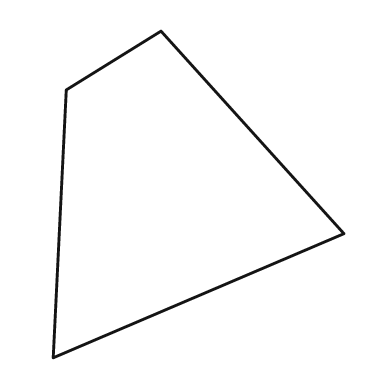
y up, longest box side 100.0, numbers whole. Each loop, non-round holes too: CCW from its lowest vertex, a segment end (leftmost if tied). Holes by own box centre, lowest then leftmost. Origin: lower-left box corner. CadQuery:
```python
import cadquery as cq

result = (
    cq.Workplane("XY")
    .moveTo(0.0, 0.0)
    .lineTo(89.0, 38.0)
    .lineTo(33.0, 100.0)
    .lineTo(4.0, 82.0)
    .close()
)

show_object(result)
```